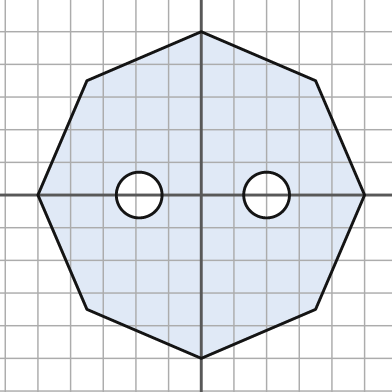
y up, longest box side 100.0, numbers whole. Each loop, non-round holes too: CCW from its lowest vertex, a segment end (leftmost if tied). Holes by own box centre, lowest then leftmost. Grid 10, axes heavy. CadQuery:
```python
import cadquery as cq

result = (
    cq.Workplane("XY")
    .moveTo(0.0, -50.0)
    .lineTo(35.0, -35.0)
    .lineTo(50.0, 0.0)
    .lineTo(35.0, 35.0)
    .lineTo(0.0, 50.0)
    .lineTo(-35.0, 35.0)
    .lineTo(-50.0, 0.0)
    .lineTo(-35.0, -35.0)
    .close()
    .moveTo(-19.0, 0.0)
    .circle(7.0)
    .moveTo(20.0, 0.0)
    .circle(7.0)
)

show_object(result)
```